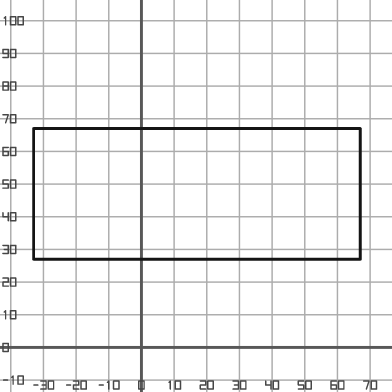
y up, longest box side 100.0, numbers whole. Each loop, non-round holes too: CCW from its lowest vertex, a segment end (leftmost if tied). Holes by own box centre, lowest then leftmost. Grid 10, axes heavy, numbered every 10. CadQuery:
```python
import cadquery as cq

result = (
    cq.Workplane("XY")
    .moveTo(-33.0, 27.0)
    .lineTo(67.0, 27.0)
    .lineTo(67.0, 67.0)
    .lineTo(-33.0, 67.0)
    .close()
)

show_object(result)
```